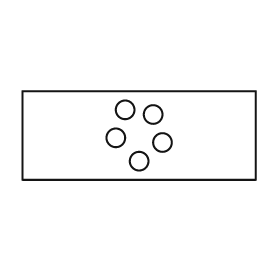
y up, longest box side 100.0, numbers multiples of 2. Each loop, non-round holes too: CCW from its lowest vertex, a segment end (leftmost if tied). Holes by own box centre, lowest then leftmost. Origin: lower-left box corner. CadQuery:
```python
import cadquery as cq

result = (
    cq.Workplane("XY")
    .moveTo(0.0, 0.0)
    .lineTo(100.0, 0.0)
    .lineTo(100.0, 38.0)
    .lineTo(0.0, 38.0)
    .close()
    .moveTo(50.0, 8.0)
    .circle(4.0)
    .moveTo(60.0, 16.0)
    .circle(4.0)
    .moveTo(40.0, 18.0)
    .circle(4.0)
    .moveTo(56.0, 28.0)
    .circle(4.0)
    .moveTo(44.0, 30.0)
    .circle(4.0)
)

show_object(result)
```